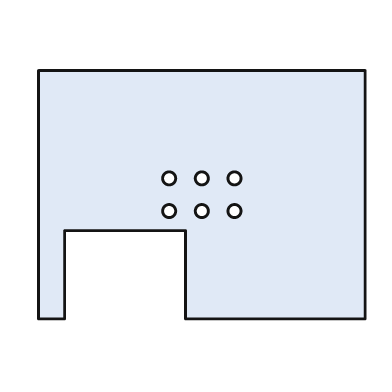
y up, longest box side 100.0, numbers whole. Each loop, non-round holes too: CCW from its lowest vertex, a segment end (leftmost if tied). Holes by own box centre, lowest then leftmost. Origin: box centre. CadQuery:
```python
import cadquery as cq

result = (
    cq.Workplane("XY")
    .moveTo(-50.0, -38.0)
    .lineTo(-42.0, -38.0)
    .lineTo(-42.0, -11.0)
    .lineTo(-5.0, -11.0)
    .lineTo(-5.0, -38.0)
    .lineTo(50.0, -38.0)
    .lineTo(50.0, 38.0)
    .lineTo(-50.0, 38.0)
    .close()
    .moveTo(-10.0, -5.0)
    .circle(2.0)
    .moveTo(0.0, -5.0)
    .circle(2.0)
    .moveTo(10.0, -5.0)
    .circle(2.0)
    .moveTo(-10.0, 5.0)
    .circle(2.0)
    .moveTo(0.0, 5.0)
    .circle(2.0)
    .moveTo(10.0, 5.0)
    .circle(2.0)
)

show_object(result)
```